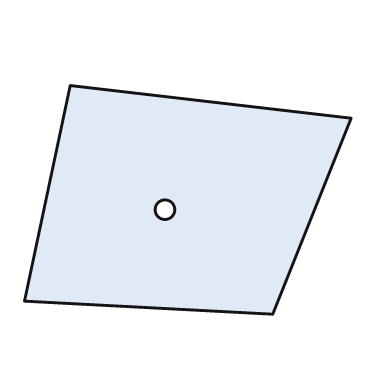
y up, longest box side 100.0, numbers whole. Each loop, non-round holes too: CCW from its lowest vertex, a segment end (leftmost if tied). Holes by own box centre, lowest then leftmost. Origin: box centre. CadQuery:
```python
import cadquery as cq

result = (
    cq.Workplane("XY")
    .moveTo(26.0, -35.0)
    .lineTo(50.0, 25.0)
    .lineTo(-36.0, 35.0)
    .lineTo(-50.0, -31.0)
    .close()
    .moveTo(-7.0, -3.0)
    .circle(3.0)
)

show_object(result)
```